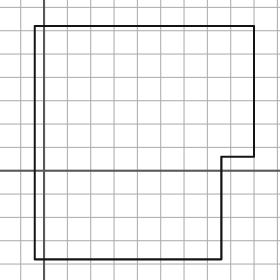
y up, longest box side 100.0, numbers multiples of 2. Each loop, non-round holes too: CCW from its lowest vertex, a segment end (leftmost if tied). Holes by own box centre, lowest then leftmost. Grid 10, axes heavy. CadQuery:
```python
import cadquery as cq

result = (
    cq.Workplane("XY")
    .moveTo(-4.0, -38.0)
    .lineTo(76.0, -38.0)
    .lineTo(76.0, 6.0)
    .lineTo(90.0, 6.0)
    .lineTo(90.0, 62.0)
    .lineTo(-4.0, 62.0)
    .close()
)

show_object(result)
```